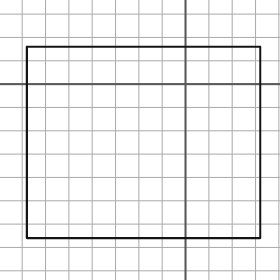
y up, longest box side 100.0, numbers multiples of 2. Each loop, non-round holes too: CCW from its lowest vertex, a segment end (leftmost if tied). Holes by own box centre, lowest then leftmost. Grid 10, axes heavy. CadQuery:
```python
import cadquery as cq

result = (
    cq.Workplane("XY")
    .moveTo(-68.0, -66.0)
    .lineTo(32.0, -66.0)
    .lineTo(32.0, 16.0)
    .lineTo(-68.0, 16.0)
    .close()
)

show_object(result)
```